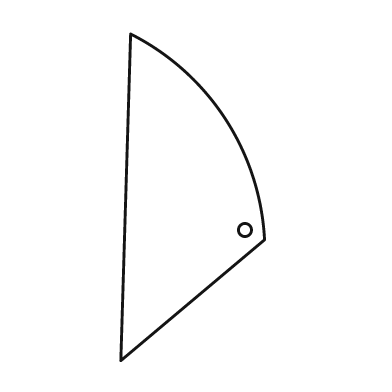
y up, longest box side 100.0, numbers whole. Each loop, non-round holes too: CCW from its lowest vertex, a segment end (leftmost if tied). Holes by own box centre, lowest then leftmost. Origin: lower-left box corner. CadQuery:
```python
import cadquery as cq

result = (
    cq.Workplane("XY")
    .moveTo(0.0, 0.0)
    .lineTo(44.0, 37.0)
    .threePointArc((32.0, 74.0), (3.0, 100.0))
    .close()
    .moveTo(38.0, 40.0)
    .circle(2.0)
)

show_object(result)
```